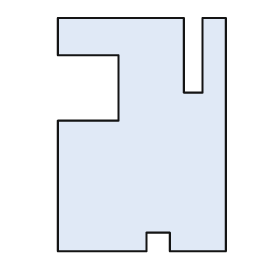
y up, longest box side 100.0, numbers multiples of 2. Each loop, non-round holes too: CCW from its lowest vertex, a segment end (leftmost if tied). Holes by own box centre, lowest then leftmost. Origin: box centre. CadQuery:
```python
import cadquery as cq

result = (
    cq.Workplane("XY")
    .moveTo(-36.0, -50.0)
    .lineTo(2.0, -50.0)
    .lineTo(2.0, -42.0)
    .lineTo(12.0, -42.0)
    .lineTo(12.0, -50.0)
    .lineTo(36.0, -50.0)
    .lineTo(36.0, 50.0)
    .lineTo(26.0, 50.0)
    .lineTo(26.0, 18.0)
    .lineTo(18.0, 18.0)
    .lineTo(18.0, 50.0)
    .lineTo(-36.0, 50.0)
    .lineTo(-36.0, 34.0)
    .lineTo(-10.0, 34.0)
    .lineTo(-10.0, 6.0)
    .lineTo(-36.0, 6.0)
    .close()
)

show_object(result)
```